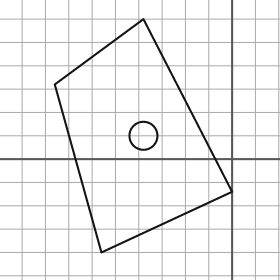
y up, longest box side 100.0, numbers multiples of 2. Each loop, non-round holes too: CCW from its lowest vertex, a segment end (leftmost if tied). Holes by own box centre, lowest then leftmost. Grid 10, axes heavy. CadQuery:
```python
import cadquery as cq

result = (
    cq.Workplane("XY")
    .moveTo(-56.0, -40.0)
    .lineTo(0.0, -14.0)
    .lineTo(-38.0, 60.0)
    .lineTo(-76.0, 32.0)
    .close()
    .moveTo(-38.0, 10.0)
    .circle(6.0)
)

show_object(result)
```